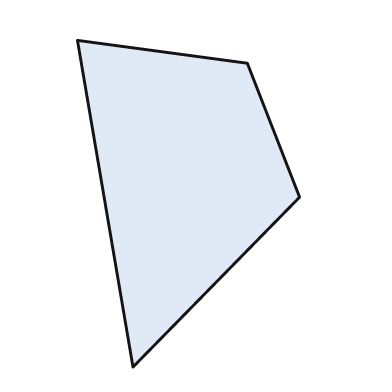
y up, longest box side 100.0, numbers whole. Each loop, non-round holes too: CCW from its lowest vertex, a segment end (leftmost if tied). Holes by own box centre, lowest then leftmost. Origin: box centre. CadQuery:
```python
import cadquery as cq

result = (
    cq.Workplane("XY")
    .moveTo(-17.0, -50.0)
    .lineTo(34.0, 2.0)
    .lineTo(18.0, 43.0)
    .lineTo(-34.0, 50.0)
    .close()
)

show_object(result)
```